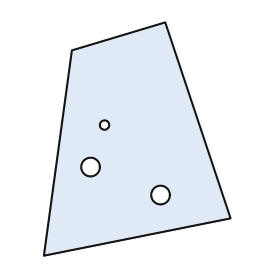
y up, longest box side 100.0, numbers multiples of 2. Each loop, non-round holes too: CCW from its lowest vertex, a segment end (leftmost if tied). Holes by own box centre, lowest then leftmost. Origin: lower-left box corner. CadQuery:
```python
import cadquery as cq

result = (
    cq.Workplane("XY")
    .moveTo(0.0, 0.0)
    .lineTo(80.0, 16.0)
    .lineTo(52.0, 100.0)
    .lineTo(12.0, 88.0)
    .close()
    .moveTo(50.0, 26.0)
    .circle(4.0)
    .moveTo(20.0, 38.0)
    .circle(4.0)
    .moveTo(26.0, 56.0)
    .circle(2.0)
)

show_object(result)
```